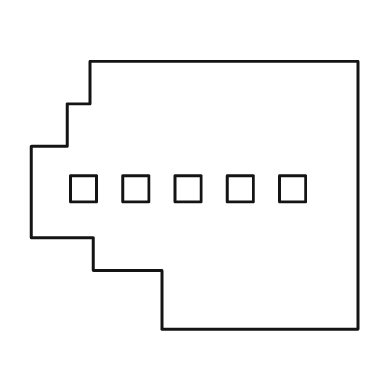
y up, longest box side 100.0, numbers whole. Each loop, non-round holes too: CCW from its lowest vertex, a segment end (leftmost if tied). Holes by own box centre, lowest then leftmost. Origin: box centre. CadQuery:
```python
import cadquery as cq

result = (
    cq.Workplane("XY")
    .moveTo(-10.0, -41.0)
    .lineTo(50.0, -41.0)
    .lineTo(50.0, 41.0)
    .lineTo(-32.0, 41.0)
    .lineTo(-32.0, 28.0)
    .lineTo(-39.0, 28.0)
    .lineTo(-39.0, 15.0)
    .lineTo(-50.0, 15.0)
    .lineTo(-50.0, -13.0)
    .lineTo(-31.0, -13.0)
    .lineTo(-31.0, -23.0)
    .lineTo(-10.0, -23.0)
    .close()
    .moveTo(-38.0, -2.0)
    .lineTo(-30.0, -2.0)
    .lineTo(-30.0, 6.0)
    .lineTo(-38.0, 6.0)
    .close()
    .moveTo(-22.0, -2.0)
    .lineTo(-14.0, -2.0)
    .lineTo(-14.0, 6.0)
    .lineTo(-22.0, 6.0)
    .close()
    .moveTo(-6.0, -2.0)
    .lineTo(2.0, -2.0)
    .lineTo(2.0, 6.0)
    .lineTo(-6.0, 6.0)
    .close()
    .moveTo(10.0, -2.0)
    .lineTo(18.0, -2.0)
    .lineTo(18.0, 6.0)
    .lineTo(10.0, 6.0)
    .close()
    .moveTo(26.0, -2.0)
    .lineTo(34.0, -2.0)
    .lineTo(34.0, 6.0)
    .lineTo(26.0, 6.0)
    .close()
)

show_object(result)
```